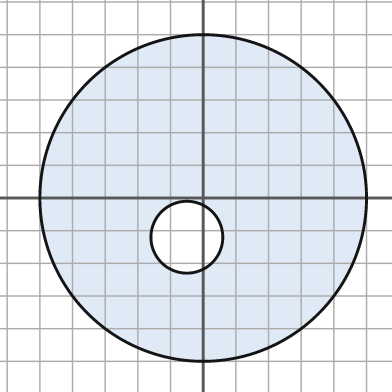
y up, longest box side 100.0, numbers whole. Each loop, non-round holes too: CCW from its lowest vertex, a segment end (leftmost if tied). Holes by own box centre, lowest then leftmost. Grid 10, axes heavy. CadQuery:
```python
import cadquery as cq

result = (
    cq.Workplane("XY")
    .moveTo(0.0, 0.0)
    .circle(50.0)
    .moveTo(-5.0, -12.0)
    .circle(11.0)
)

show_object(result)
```